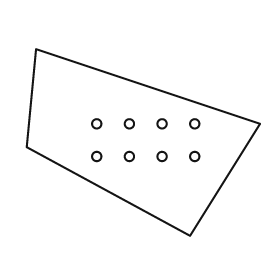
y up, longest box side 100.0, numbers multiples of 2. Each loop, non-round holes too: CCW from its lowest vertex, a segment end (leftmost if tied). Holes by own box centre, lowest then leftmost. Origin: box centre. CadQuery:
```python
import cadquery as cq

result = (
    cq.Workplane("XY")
    .moveTo(20.0, -40.0)
    .lineTo(50.0, 8.0)
    .lineTo(-46.0, 40.0)
    .lineTo(-50.0, -2.0)
    .close()
    .moveTo(-20.0, -6.0)
    .circle(2.0)
    .moveTo(-6.0, -6.0)
    .circle(2.0)
    .moveTo(8.0, -6.0)
    .circle(2.0)
    .moveTo(22.0, -6.0)
    .circle(2.0)
    .moveTo(-20.0, 8.0)
    .circle(2.0)
    .moveTo(-6.0, 8.0)
    .circle(2.0)
    .moveTo(8.0, 8.0)
    .circle(2.0)
    .moveTo(22.0, 8.0)
    .circle(2.0)
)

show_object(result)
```